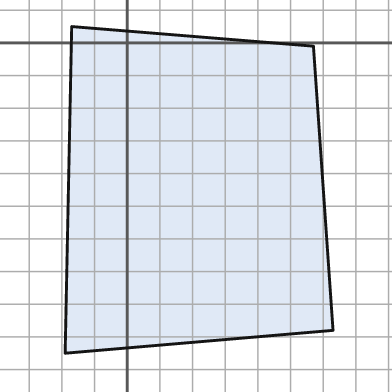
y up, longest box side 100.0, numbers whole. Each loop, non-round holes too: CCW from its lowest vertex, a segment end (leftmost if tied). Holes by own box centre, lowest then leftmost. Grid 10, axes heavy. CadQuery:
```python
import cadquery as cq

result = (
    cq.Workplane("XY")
    .moveTo(-19.0, -95.0)
    .lineTo(63.0, -88.0)
    .lineTo(57.0, -1.0)
    .lineTo(-17.0, 5.0)
    .close()
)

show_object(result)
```